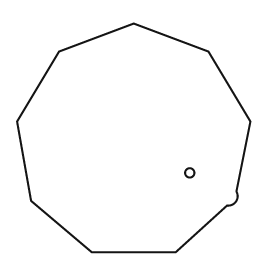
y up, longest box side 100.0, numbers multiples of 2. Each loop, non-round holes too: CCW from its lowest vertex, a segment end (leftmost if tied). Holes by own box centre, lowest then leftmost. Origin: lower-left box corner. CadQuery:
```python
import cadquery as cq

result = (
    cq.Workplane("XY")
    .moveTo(32.0, 0.0)
    .lineTo(68.0, 0.0)
    .lineTo(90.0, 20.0)
    .threePointArc((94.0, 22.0), (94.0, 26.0))
    .lineTo(100.0, 56.0)
    .lineTo(82.0, 86.0)
    .lineTo(50.0, 98.0)
    .lineTo(18.0, 86.0)
    .lineTo(0.0, 56.0)
    .lineTo(6.0, 22.0)
    .close()
    .moveTo(74.0, 34.0)
    .circle(2.0)
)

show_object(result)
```